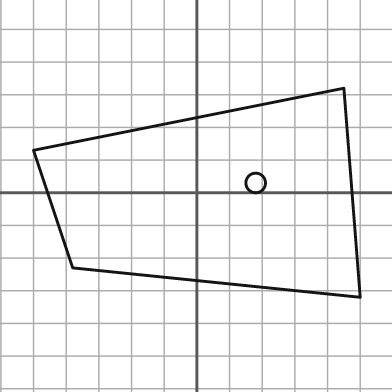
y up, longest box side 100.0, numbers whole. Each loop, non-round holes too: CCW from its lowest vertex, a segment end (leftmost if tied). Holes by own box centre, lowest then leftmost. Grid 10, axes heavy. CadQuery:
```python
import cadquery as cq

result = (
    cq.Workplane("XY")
    .moveTo(50.0, -32.0)
    .lineTo(45.0, 32.0)
    .lineTo(-50.0, 13.0)
    .lineTo(-38.0, -23.0)
    .close()
    .moveTo(18.0, 3.0)
    .circle(3.0)
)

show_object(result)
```